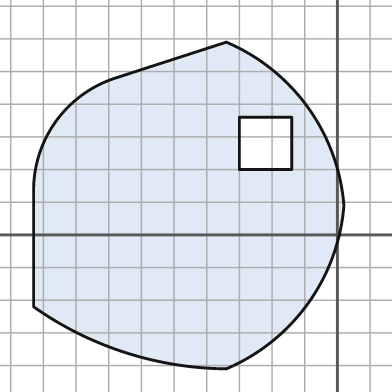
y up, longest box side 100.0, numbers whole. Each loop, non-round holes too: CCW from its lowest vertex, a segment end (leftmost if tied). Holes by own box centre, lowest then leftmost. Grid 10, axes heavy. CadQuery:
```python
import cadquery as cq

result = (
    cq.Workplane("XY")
    .moveTo(-34.0, -41.0)
    .threePointArc((-9.0, -21.0), (2.0, 9.0))
    .threePointArc((-9.0, 39.0), (-34.0, 59.0))
    .lineTo(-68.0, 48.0)
    .threePointArc((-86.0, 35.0), (-93.0, 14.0))
    .lineTo(-93.0, -22.0)
    .threePointArc((-65.0, -36.0), (-34.0, -41.0))
    .close()
    .moveTo(-30.0, 20.0)
    .lineTo(-14.0, 20.0)
    .lineTo(-14.0, 36.0)
    .lineTo(-30.0, 36.0)
    .close()
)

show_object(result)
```